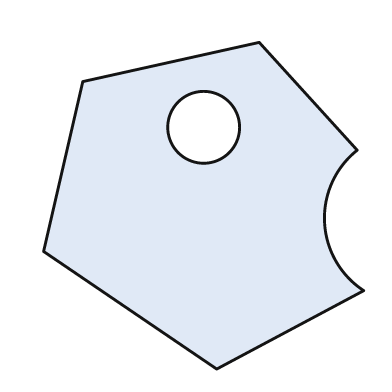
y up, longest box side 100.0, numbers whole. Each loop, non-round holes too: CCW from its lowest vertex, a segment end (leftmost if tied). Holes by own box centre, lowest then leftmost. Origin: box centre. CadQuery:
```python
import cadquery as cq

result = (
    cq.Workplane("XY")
    .moveTo(4.0, -50.0)
    .lineTo(49.0, -26.0)
    .threePointArc((37.0, -5.0), (47.0, 17.0))
    .lineTo(17.0, 50.0)
    .lineTo(-37.0, 38.0)
    .lineTo(-49.0, -14.0)
    .close()
    .moveTo(0.0, 24.0)
    .circle(11.0)
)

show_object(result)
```